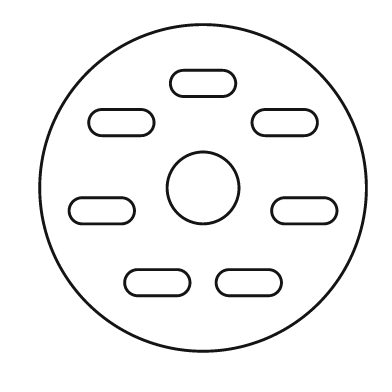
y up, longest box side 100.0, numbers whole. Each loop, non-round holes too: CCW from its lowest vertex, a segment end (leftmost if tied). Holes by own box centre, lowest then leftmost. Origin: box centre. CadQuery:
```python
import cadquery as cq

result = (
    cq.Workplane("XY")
    .moveTo(0.0, 0.0)
    .circle(50.0)
    .moveTo(-20.0, -33.0)
    .lineTo(-8.0, -33.0)
    .threePointArc((-4.0, -29.0), (-8.0, -25.0))
    .lineTo(-20.0, -25.0)
    .threePointArc((-24.0, -29.0), (-20.0, -33.0))
    .close()
    .moveTo(8.0, -33.0)
    .lineTo(20.0, -33.0)
    .threePointArc((24.0, -29.0), (20.0, -25.0))
    .lineTo(8.0, -25.0)
    .threePointArc((4.0, -29.0), (8.0, -33.0))
    .close()
    .moveTo(-37.0, -11.0)
    .lineTo(-25.0, -11.0)
    .threePointArc((-21.0, -7.0), (-25.0, -3.0))
    .lineTo(-37.0, -3.0)
    .threePointArc((-41.0, -7.0), (-37.0, -11.0))
    .close()
    .moveTo(25.0, -11.0)
    .lineTo(37.0, -11.0)
    .threePointArc((41.0, -7.0), (37.0, -3.0))
    .lineTo(25.0, -3.0)
    .threePointArc((21.0, -7.0), (25.0, -11.0))
    .close()
    .moveTo(0.0, 0.0)
    .circle(11.0)
    .moveTo(-31.0, 16.0)
    .lineTo(-19.0, 16.0)
    .threePointArc((-15.0, 20.0), (-19.0, 24.0))
    .lineTo(-31.0, 24.0)
    .threePointArc((-35.0, 20.0), (-31.0, 16.0))
    .close()
    .moveTo(19.0, 16.0)
    .lineTo(31.0, 16.0)
    .threePointArc((35.0, 20.0), (31.0, 24.0))
    .lineTo(19.0, 24.0)
    .threePointArc((15.0, 20.0), (19.0, 16.0))
    .close()
    .moveTo(-6.0, 28.0)
    .lineTo(6.0, 28.0)
    .threePointArc((10.0, 32.0), (6.0, 36.0))
    .lineTo(-6.0, 36.0)
    .threePointArc((-10.0, 32.0), (-6.0, 28.0))
    .close()
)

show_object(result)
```